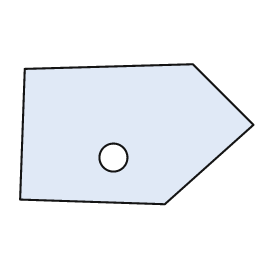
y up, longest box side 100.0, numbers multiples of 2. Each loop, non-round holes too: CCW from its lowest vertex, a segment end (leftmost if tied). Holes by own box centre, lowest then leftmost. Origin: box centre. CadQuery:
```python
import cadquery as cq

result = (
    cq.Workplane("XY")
    .moveTo(12.0, -30.0)
    .lineTo(50.0, 4.0)
    .lineTo(24.0, 30.0)
    .lineTo(-48.0, 28.0)
    .lineTo(-50.0, -28.0)
    .close()
    .moveTo(-10.0, -10.0)
    .circle(6.0)
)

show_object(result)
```